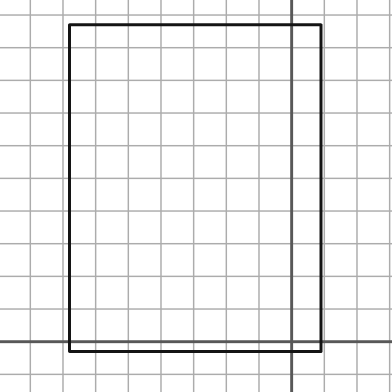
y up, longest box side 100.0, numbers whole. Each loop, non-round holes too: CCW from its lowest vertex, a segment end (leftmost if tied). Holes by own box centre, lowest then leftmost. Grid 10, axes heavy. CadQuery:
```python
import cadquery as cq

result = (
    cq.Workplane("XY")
    .moveTo(-68.0, -3.0)
    .lineTo(9.0, -3.0)
    .lineTo(9.0, 97.0)
    .lineTo(-68.0, 97.0)
    .close()
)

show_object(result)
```